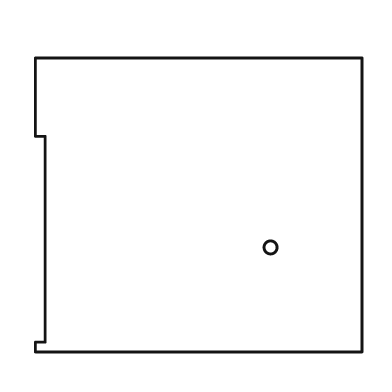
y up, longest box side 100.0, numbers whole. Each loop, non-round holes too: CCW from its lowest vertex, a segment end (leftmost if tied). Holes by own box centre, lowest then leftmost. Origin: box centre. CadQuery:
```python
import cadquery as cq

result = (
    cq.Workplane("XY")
    .moveTo(-50.0, -45.0)
    .lineTo(50.0, -45.0)
    .lineTo(50.0, 45.0)
    .lineTo(-50.0, 45.0)
    .lineTo(-50.0, 21.0)
    .lineTo(-47.0, 21.0)
    .lineTo(-47.0, -42.0)
    .lineTo(-50.0, -42.0)
    .close()
    .moveTo(22.0, -13.0)
    .circle(2.0)
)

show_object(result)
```